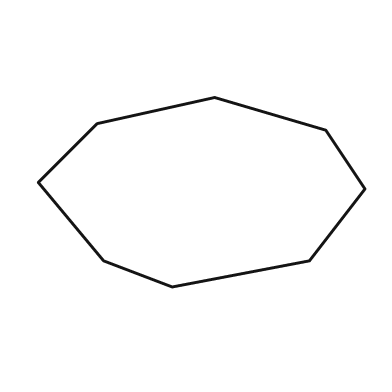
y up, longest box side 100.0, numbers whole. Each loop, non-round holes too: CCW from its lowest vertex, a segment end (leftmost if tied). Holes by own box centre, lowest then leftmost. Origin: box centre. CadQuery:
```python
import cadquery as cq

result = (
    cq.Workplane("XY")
    .moveTo(-9.0, -29.0)
    .lineTo(33.0, -21.0)
    .lineTo(50.0, 1.0)
    .lineTo(38.0, 19.0)
    .lineTo(4.0, 29.0)
    .lineTo(-32.0, 21.0)
    .lineTo(-50.0, 3.0)
    .lineTo(-30.0, -21.0)
    .close()
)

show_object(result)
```